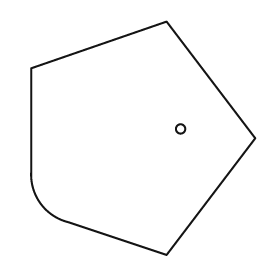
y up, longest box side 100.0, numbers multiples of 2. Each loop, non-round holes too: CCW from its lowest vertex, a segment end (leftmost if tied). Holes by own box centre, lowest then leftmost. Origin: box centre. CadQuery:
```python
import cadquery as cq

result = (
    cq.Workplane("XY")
    .moveTo(10.0, -50.0)
    .lineTo(48.0, 0.0)
    .lineTo(10.0, 50.0)
    .lineTo(-48.0, 30.0)
    .lineTo(-48.0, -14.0)
    .threePointArc((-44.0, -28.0), (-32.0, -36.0))
    .close()
    .moveTo(16.0, 4.0)
    .circle(2.0)
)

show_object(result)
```